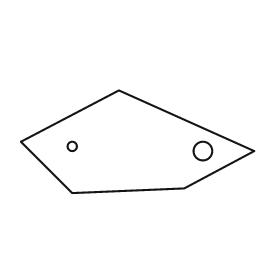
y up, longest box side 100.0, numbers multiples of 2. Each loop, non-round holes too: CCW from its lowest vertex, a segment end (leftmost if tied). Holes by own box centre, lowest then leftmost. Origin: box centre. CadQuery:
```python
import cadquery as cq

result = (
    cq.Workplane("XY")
    .moveTo(-28.0, -22.0)
    .lineTo(20.0, -20.0)
    .lineTo(50.0, -4.0)
    .lineTo(-8.0, 22.0)
    .lineTo(-50.0, 0.0)
    .close()
    .moveTo(28.0, -4.0)
    .circle(4.0)
    .moveTo(-28.0, -2.0)
    .circle(2.0)
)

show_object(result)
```